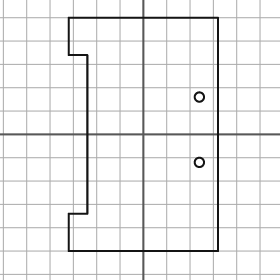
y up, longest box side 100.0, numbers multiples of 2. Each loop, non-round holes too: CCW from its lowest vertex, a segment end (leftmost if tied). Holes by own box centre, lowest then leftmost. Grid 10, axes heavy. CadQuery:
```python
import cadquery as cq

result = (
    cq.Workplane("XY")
    .moveTo(-32.0, -50.0)
    .lineTo(32.0, -50.0)
    .lineTo(32.0, 50.0)
    .lineTo(-32.0, 50.0)
    .lineTo(-32.0, 34.0)
    .lineTo(-24.0, 34.0)
    .lineTo(-24.0, -34.0)
    .lineTo(-32.0, -34.0)
    .close()
    .moveTo(24.0, -12.0)
    .circle(2.0)
    .moveTo(24.0, 16.0)
    .circle(2.0)
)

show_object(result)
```